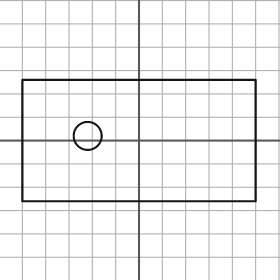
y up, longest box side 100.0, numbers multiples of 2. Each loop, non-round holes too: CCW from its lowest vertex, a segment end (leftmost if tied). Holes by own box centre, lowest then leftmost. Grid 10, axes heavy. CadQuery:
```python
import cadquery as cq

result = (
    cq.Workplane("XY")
    .moveTo(-50.0, -26.0)
    .lineTo(50.0, -26.0)
    .lineTo(50.0, 26.0)
    .lineTo(-50.0, 26.0)
    .close()
    .moveTo(-22.0, 2.0)
    .circle(6.0)
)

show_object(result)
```